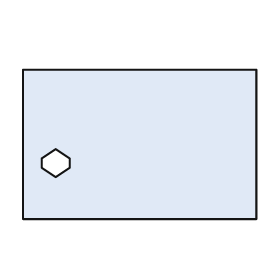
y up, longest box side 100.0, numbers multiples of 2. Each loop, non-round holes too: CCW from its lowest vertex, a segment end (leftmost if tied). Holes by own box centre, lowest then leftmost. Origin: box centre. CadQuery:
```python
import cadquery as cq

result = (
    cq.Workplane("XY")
    .moveTo(-50.0, -32.0)
    .lineTo(50.0, -32.0)
    .lineTo(50.0, 32.0)
    .lineTo(-50.0, 32.0)
    .close()
    .moveTo(-36.0, -14.0)
    .lineTo(-30.0, -10.0)
    .lineTo(-30.0, -6.0)
    .lineTo(-36.0, -2.0)
    .lineTo(-42.0, -6.0)
    .lineTo(-42.0, -10.0)
    .close()
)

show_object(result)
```